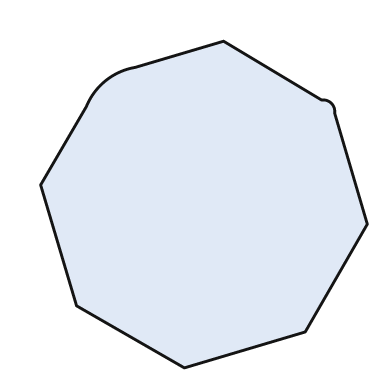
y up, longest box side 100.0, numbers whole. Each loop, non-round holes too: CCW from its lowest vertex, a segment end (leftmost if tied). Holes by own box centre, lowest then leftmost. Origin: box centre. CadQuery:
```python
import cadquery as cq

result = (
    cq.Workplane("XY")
    .moveTo(-6.0, -50.0)
    .lineTo(31.0, -39.0)
    .lineTo(50.0, -6.0)
    .lineTo(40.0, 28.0)
    .threePointArc((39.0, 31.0), (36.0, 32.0))
    .lineTo(6.0, 50.0)
    .lineTo(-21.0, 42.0)
    .threePointArc((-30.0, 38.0), (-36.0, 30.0))
    .lineTo(-50.0, 6.0)
    .lineTo(-39.0, -31.0)
    .close()
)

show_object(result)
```